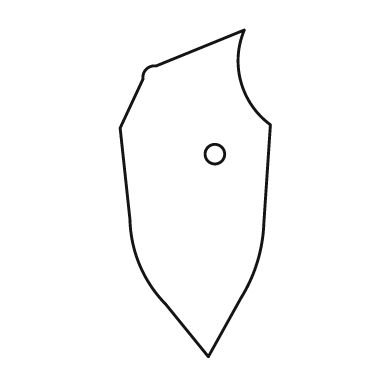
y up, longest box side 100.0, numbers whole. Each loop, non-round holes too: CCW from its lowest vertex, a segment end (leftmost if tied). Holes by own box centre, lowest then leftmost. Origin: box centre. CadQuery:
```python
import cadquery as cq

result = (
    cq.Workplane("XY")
    .moveTo(4.0, -50.0)
    .lineTo(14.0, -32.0)
    .threePointArc((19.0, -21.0), (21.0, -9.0))
    .lineTo(23.0, 21.0)
    .threePointArc((14.0, 34.0), (15.0, 50.0))
    .lineTo(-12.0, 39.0)
    .threePointArc((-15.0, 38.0), (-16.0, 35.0))
    .lineTo(-23.0, 20.0)
    .lineTo(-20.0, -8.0)
    .threePointArc((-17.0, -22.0), (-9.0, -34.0))
    .close()
    .moveTo(6.0, 12.0)
    .circle(3.0)
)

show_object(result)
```